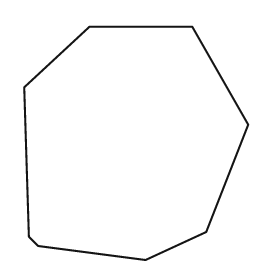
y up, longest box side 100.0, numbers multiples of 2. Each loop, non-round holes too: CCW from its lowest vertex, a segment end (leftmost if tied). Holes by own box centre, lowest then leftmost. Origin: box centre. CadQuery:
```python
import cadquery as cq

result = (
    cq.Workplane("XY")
    .moveTo(4.0, -50.0)
    .lineTo(30.0, -38.0)
    .lineTo(48.0, 8.0)
    .lineTo(24.0, 50.0)
    .lineTo(-20.0, 50.0)
    .lineTo(-48.0, 24.0)
    .lineTo(-46.0, -40.0)
    .lineTo(-42.0, -44.0)
    .close()
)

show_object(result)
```